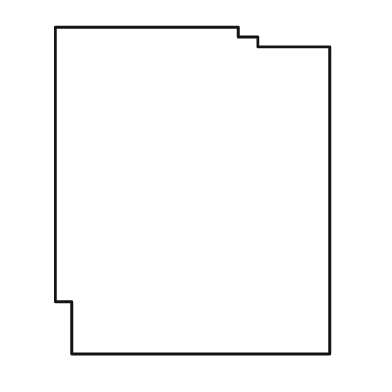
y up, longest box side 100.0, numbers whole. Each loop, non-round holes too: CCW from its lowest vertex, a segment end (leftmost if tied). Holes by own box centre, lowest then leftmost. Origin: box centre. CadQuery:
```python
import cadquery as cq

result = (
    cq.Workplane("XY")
    .moveTo(-37.0, -50.0)
    .lineTo(42.0, -50.0)
    .lineTo(42.0, 44.0)
    .lineTo(20.0, 44.0)
    .lineTo(20.0, 47.0)
    .lineTo(14.0, 47.0)
    .lineTo(14.0, 50.0)
    .lineTo(-42.0, 50.0)
    .lineTo(-42.0, -34.0)
    .lineTo(-37.0, -34.0)
    .close()
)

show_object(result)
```